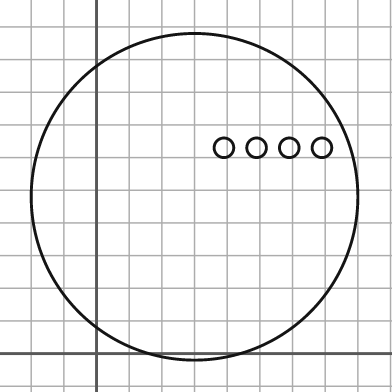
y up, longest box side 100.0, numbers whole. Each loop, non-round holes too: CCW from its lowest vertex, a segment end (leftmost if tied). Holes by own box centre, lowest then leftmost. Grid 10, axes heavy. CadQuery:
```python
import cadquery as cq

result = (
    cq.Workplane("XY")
    .moveTo(30.0, 48.0)
    .circle(50.0)
    .moveTo(39.0, 63.0)
    .circle(3.0)
    .moveTo(49.0, 63.0)
    .circle(3.0)
    .moveTo(59.0, 63.0)
    .circle(3.0)
    .moveTo(69.0, 63.0)
    .circle(3.0)
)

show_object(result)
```